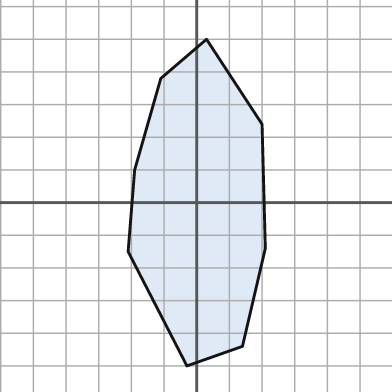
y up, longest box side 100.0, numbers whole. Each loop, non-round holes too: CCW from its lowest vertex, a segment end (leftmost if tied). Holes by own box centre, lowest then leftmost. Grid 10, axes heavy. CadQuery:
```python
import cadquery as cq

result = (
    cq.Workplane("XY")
    .moveTo(-3.0, -50.0)
    .lineTo(14.0, -44.0)
    .lineTo(21.0, -14.0)
    .lineTo(20.0, 24.0)
    .lineTo(3.0, 50.0)
    .lineTo(-11.0, 38.0)
    .lineTo(-19.0, 10.0)
    .lineTo(-21.0, -15.0)
    .close()
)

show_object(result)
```